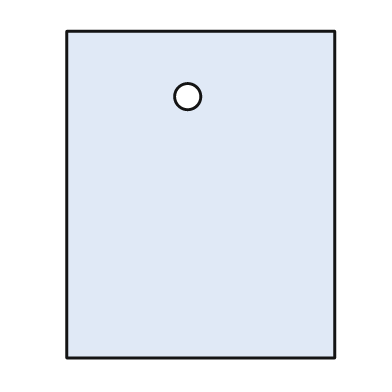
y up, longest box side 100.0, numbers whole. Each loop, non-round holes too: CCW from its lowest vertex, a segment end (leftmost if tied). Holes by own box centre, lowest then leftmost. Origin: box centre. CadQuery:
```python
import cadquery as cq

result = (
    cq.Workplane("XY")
    .moveTo(-41.0, -50.0)
    .lineTo(41.0, -50.0)
    .lineTo(41.0, 50.0)
    .lineTo(-41.0, 50.0)
    .close()
    .moveTo(-4.0, 30.0)
    .circle(4.0)
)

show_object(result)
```